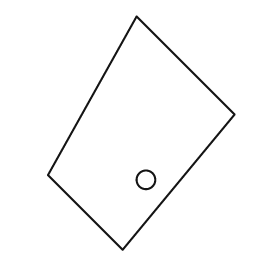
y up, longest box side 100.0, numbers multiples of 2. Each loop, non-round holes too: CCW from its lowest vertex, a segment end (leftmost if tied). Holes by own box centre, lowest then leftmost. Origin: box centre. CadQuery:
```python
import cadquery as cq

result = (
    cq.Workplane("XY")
    .moveTo(-8.0, -50.0)
    .lineTo(40.0, 8.0)
    .lineTo(-2.0, 50.0)
    .lineTo(-40.0, -18.0)
    .close()
    .moveTo(2.0, -20.0)
    .circle(4.0)
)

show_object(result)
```